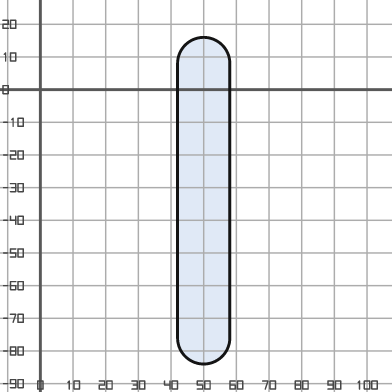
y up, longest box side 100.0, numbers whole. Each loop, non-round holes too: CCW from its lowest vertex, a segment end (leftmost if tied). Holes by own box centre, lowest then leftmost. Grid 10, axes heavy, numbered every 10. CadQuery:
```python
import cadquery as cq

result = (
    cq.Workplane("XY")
    .moveTo(42.0, -76.0)
    .threePointArc((50.0, -84.0), (58.0, -76.0))
    .lineTo(58.0, 8.0)
    .threePointArc((50.0, 16.0), (42.0, 8.0))
    .close()
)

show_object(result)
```